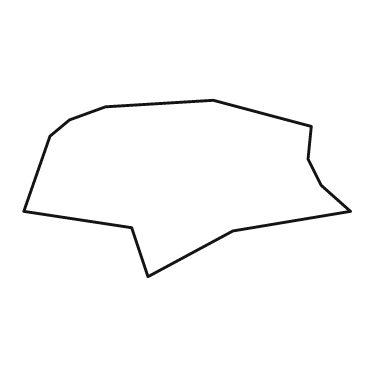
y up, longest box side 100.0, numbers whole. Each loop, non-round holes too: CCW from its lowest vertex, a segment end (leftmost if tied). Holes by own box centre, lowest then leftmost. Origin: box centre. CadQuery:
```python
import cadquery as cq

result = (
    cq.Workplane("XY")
    .moveTo(-12.0, -27.0)
    .lineTo(14.0, -13.0)
    .lineTo(50.0, -7.0)
    .lineTo(41.0, 1.0)
    .lineTo(37.0, 9.0)
    .lineTo(38.0, 19.0)
    .lineTo(8.0, 27.0)
    .lineTo(-25.0, 25.0)
    .lineTo(-36.0, 21.0)
    .lineTo(-42.0, 16.0)
    .lineTo(-50.0, -7.0)
    .lineTo(-17.0, -12.0)
    .close()
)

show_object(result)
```